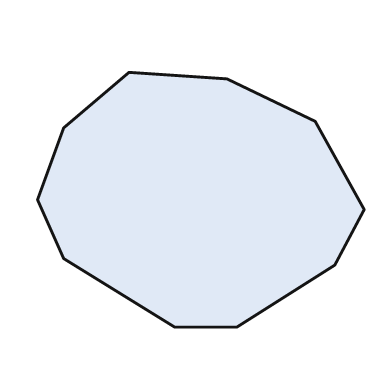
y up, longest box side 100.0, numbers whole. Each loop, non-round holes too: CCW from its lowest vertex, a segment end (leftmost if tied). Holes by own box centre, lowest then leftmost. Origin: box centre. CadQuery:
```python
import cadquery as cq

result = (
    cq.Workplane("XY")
    .moveTo(-8.0, -39.0)
    .lineTo(11.0, -39.0)
    .lineTo(41.0, -20.0)
    .lineTo(50.0, -3.0)
    .lineTo(35.0, 24.0)
    .lineTo(8.0, 37.0)
    .lineTo(-22.0, 39.0)
    .lineTo(-42.0, 22.0)
    .lineTo(-50.0, 0.0)
    .lineTo(-42.0, -18.0)
    .close()
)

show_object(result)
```